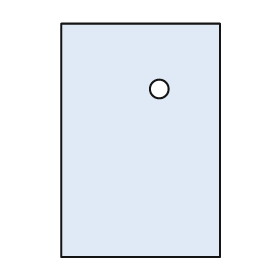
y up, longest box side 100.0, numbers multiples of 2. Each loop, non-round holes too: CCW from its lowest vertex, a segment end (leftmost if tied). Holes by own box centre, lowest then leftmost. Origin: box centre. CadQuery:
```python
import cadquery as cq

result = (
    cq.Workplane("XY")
    .moveTo(-34.0, -50.0)
    .lineTo(34.0, -50.0)
    .lineTo(34.0, 50.0)
    .lineTo(-34.0, 50.0)
    .close()
    .moveTo(8.0, 22.0)
    .circle(4.0)
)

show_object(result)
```